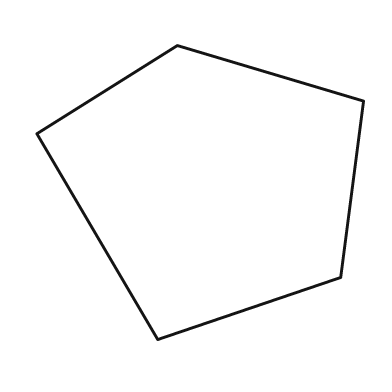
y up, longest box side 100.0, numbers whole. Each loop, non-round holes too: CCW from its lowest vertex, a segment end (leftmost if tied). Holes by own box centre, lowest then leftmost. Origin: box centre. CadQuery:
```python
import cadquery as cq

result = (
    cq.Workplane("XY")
    .moveTo(-13.0, -45.0)
    .lineTo(43.0, -26.0)
    .lineTo(50.0, 28.0)
    .lineTo(-7.0, 45.0)
    .lineTo(-50.0, 18.0)
    .close()
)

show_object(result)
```